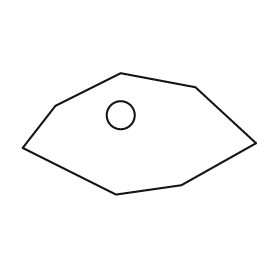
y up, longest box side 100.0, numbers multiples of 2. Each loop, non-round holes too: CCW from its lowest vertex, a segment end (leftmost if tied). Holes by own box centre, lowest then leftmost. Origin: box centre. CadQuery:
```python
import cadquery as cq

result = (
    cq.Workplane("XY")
    .moveTo(-10.0, -26.0)
    .lineTo(18.0, -22.0)
    .lineTo(50.0, -4.0)
    .lineTo(24.0, 20.0)
    .lineTo(-8.0, 26.0)
    .lineTo(-36.0, 12.0)
    .lineTo(-50.0, -6.0)
    .close()
    .moveTo(-8.0, 8.0)
    .circle(6.0)
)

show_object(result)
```